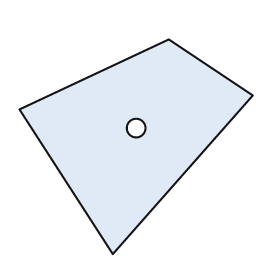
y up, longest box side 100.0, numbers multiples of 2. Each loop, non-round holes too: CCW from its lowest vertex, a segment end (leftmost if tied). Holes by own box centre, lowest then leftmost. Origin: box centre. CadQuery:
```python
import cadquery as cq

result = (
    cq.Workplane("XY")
    .moveTo(-10.0, -46.0)
    .lineTo(50.0, 22.0)
    .lineTo(14.0, 46.0)
    .lineTo(-50.0, 16.0)
    .close()
    .moveTo(0.0, 8.0)
    .circle(4.0)
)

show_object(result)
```